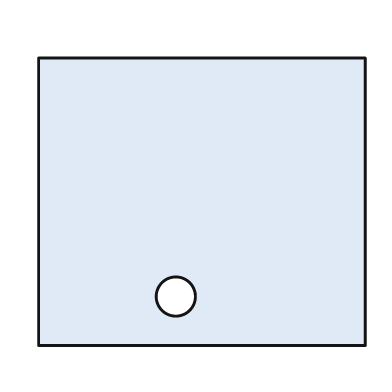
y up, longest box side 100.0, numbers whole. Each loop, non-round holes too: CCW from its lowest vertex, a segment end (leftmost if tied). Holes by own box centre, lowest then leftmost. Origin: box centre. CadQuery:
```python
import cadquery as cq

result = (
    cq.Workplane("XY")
    .moveTo(-50.0, -44.0)
    .lineTo(50.0, -44.0)
    .lineTo(50.0, 44.0)
    .lineTo(-50.0, 44.0)
    .close()
    .moveTo(-8.0, -29.0)
    .circle(6.0)
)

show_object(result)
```